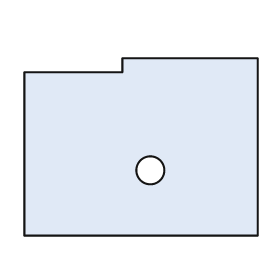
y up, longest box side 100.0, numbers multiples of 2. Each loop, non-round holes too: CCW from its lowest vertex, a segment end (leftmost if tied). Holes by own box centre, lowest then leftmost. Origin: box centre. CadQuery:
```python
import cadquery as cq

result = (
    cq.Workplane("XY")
    .moveTo(-50.0, -38.0)
    .lineTo(50.0, -38.0)
    .lineTo(50.0, 38.0)
    .lineTo(-8.0, 38.0)
    .lineTo(-8.0, 32.0)
    .lineTo(-50.0, 32.0)
    .close()
    .moveTo(4.0, -10.0)
    .circle(6.0)
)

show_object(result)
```